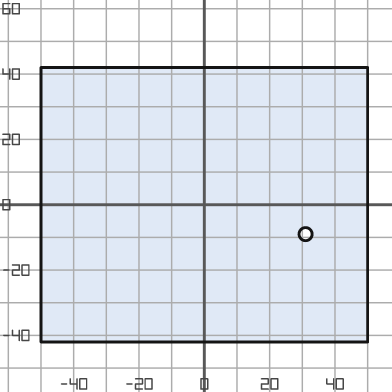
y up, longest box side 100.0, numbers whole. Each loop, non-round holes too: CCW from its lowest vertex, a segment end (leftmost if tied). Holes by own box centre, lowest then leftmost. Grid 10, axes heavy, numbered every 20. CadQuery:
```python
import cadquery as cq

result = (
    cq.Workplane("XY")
    .moveTo(-50.0, -42.0)
    .lineTo(50.0, -42.0)
    .lineTo(50.0, 42.0)
    .lineTo(-50.0, 42.0)
    .close()
    .moveTo(31.0, -9.0)
    .circle(2.0)
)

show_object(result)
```